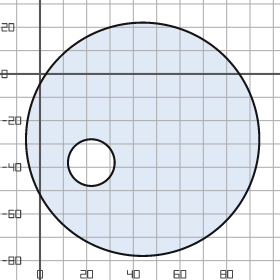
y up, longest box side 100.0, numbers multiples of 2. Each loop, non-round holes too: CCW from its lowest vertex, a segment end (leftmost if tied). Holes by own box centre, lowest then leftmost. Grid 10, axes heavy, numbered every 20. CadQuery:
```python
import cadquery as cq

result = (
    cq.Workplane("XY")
    .moveTo(44.0, -28.0)
    .circle(50.0)
    .moveTo(22.0, -38.0)
    .circle(10.0)
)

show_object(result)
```